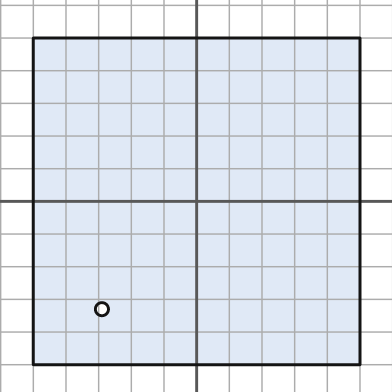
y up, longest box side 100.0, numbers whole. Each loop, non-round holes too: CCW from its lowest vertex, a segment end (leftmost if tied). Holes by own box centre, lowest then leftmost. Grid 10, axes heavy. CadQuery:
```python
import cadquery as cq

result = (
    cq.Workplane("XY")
    .moveTo(-50.0, -50.0)
    .lineTo(50.0, -50.0)
    .lineTo(50.0, 50.0)
    .lineTo(-50.0, 50.0)
    .close()
    .moveTo(-29.0, -33.0)
    .circle(2.0)
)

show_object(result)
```